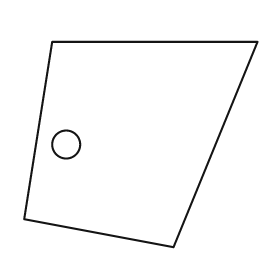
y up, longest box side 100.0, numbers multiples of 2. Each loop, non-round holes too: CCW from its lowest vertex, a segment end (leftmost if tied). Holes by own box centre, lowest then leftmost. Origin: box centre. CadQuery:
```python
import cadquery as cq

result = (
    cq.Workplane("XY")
    .moveTo(14.0, -44.0)
    .lineTo(50.0, 44.0)
    .lineTo(-38.0, 44.0)
    .lineTo(-50.0, -32.0)
    .close()
    .moveTo(-32.0, 0.0)
    .circle(6.0)
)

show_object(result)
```